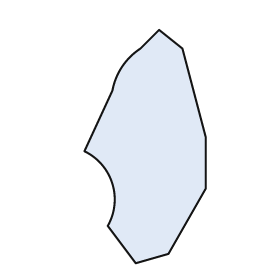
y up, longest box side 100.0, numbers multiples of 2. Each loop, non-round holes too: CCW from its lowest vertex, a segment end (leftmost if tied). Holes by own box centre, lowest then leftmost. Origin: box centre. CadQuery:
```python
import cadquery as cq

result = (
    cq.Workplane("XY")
    .moveTo(-4.0, -50.0)
    .lineTo(10.0, -46.0)
    .lineTo(26.0, -18.0)
    .lineTo(26.0, 4.0)
    .lineTo(16.0, 42.0)
    .lineTo(6.0, 50.0)
    .lineTo(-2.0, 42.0)
    .threePointArc((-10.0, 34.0), (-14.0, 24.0))
    .lineTo(-26.0, -2.0)
    .threePointArc((-14.0, -16.0), (-16.0, -34.0))
    .close()
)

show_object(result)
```